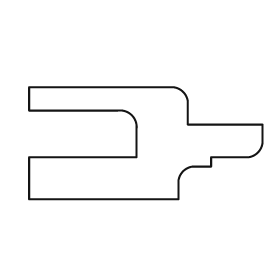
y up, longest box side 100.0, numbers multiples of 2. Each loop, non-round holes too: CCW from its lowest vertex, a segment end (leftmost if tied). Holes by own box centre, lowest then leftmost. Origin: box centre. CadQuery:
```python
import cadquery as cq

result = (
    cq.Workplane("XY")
    .moveTo(-50.0, -24.0)
    .lineTo(14.0, -24.0)
    .lineTo(14.0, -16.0)
    .threePointArc((16.0, -12.0), (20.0, -10.0))
    .lineTo(28.0, -10.0)
    .lineTo(28.0, -6.0)
    .lineTo(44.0, -6.0)
    .threePointArc((48.0, -4.0), (50.0, 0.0))
    .lineTo(50.0, 8.0)
    .lineTo(18.0, 8.0)
    .lineTo(18.0, 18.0)
    .threePointArc((16.0, 22.0), (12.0, 24.0))
    .lineTo(-50.0, 24.0)
    .lineTo(-50.0, 14.0)
    .lineTo(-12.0, 14.0)
    .threePointArc((-6.0, 12.0), (-4.0, 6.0))
    .lineTo(-4.0, -6.0)
    .lineTo(-50.0, -6.0)
    .close()
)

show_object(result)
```